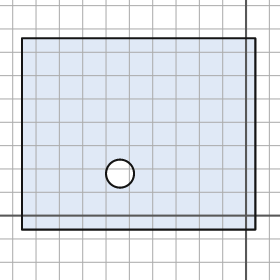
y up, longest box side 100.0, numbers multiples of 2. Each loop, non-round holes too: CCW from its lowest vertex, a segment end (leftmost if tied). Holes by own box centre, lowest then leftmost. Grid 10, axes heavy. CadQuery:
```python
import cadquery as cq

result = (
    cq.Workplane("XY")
    .moveTo(-96.0, -6.0)
    .lineTo(4.0, -6.0)
    .lineTo(4.0, 76.0)
    .lineTo(-96.0, 76.0)
    .close()
    .moveTo(-54.0, 18.0)
    .circle(6.0)
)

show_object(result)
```